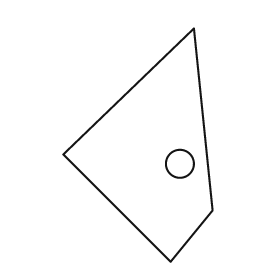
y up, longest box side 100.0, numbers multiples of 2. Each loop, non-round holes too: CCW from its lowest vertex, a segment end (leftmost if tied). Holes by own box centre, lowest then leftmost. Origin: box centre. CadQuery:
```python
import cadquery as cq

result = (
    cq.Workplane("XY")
    .moveTo(14.0, -50.0)
    .lineTo(32.0, -28.0)
    .lineTo(24.0, 50.0)
    .lineTo(-32.0, -4.0)
    .close()
    .moveTo(18.0, -8.0)
    .circle(6.0)
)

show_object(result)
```